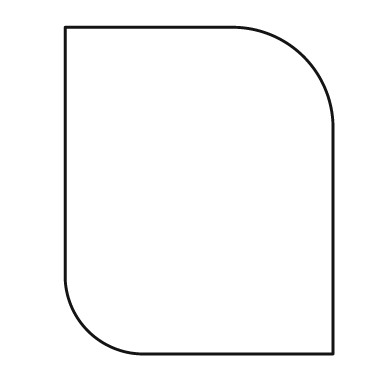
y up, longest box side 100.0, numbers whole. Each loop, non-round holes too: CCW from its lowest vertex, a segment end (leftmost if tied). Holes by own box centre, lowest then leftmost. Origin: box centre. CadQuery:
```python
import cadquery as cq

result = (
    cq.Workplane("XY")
    .moveTo(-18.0, -50.0)
    .lineTo(41.0, -50.0)
    .lineTo(41.0, 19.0)
    .threePointArc((32.0, 41.0), (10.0, 50.0))
    .lineTo(-41.0, 50.0)
    .lineTo(-41.0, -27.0)
    .threePointArc((-34.0, -43.0), (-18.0, -50.0))
    .close()
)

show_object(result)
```